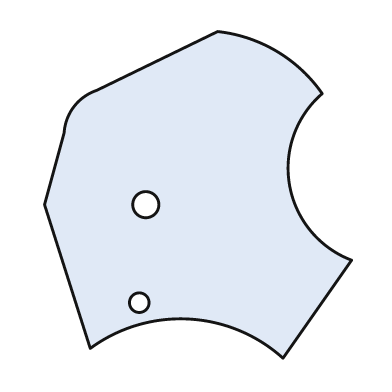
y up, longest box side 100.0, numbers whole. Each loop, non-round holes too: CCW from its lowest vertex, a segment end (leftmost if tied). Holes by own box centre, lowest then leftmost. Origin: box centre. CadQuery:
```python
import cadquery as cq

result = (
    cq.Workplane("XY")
    .moveTo(26.0, -50.0)
    .lineTo(47.0, -20.0)
    .threePointArc((28.0, 3.0), (38.0, 31.0))
    .threePointArc((24.0, 44.0), (6.0, 50.0))
    .lineTo(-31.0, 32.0)
    .threePointArc((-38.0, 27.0), (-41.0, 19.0))
    .lineTo(-47.0, -3.0)
    .lineTo(-33.0, -47.0)
    .threePointArc((-3.0, -38.0), (26.0, -50.0))
    .close()
    .moveTo(-18.0, -33.0)
    .circle(3.0)
    .moveTo(-16.0, -3.0)
    .circle(4.0)
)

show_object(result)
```